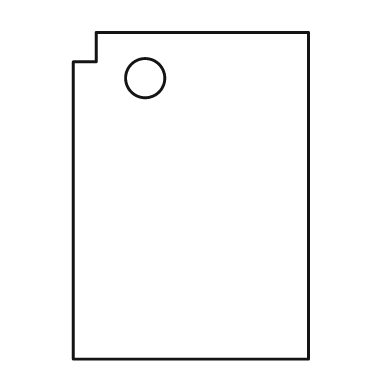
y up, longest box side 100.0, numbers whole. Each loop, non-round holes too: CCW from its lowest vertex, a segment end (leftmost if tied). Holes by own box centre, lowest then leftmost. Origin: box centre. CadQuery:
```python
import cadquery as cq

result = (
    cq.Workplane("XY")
    .moveTo(-36.0, -50.0)
    .lineTo(36.0, -50.0)
    .lineTo(36.0, 50.0)
    .lineTo(-29.0, 50.0)
    .lineTo(-29.0, 41.0)
    .lineTo(-36.0, 41.0)
    .close()
    .moveTo(-14.0, 36.0)
    .circle(6.0)
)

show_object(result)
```